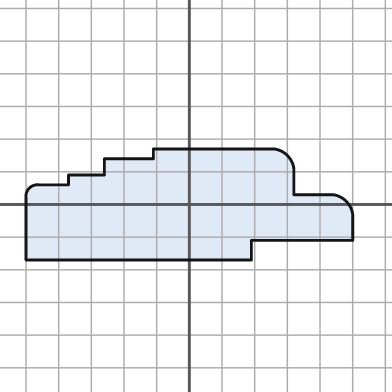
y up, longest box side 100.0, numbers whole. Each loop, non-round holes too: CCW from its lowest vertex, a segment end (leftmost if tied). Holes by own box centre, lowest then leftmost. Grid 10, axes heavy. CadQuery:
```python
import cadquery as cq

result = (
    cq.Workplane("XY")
    .moveTo(-50.0, -17.0)
    .lineTo(19.0, -17.0)
    .lineTo(19.0, -11.0)
    .lineTo(50.0, -11.0)
    .lineTo(50.0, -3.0)
    .threePointArc((48.0, 1.0), (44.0, 3.0))
    .lineTo(32.0, 3.0)
    .lineTo(32.0, 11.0)
    .threePointArc((30.0, 15.0), (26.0, 17.0))
    .lineTo(-11.0, 17.0)
    .lineTo(-11.0, 14.0)
    .lineTo(-26.0, 14.0)
    .lineTo(-26.0, 9.0)
    .lineTo(-37.0, 9.0)
    .lineTo(-37.0, 6.0)
    .lineTo(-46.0, 6.0)
    .threePointArc((-49.0, 5.0), (-50.0, 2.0))
    .close()
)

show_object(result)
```